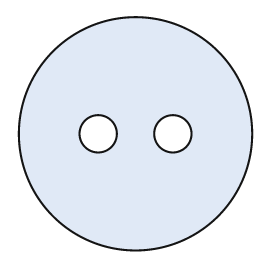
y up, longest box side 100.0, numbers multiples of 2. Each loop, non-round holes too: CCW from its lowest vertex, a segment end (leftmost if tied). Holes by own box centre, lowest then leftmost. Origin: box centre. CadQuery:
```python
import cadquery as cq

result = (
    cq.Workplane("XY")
    .moveTo(0.0, 0.0)
    .circle(50.0)
    .moveTo(-16.0, 0.0)
    .circle(8.0)
    .moveTo(16.0, 0.0)
    .circle(8.0)
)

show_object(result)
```